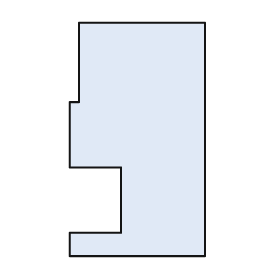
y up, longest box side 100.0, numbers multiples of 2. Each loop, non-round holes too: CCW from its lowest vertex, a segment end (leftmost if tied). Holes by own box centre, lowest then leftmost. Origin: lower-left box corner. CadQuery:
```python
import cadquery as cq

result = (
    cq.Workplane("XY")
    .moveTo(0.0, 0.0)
    .lineTo(58.0, 0.0)
    .lineTo(58.0, 100.0)
    .lineTo(4.0, 100.0)
    .lineTo(4.0, 66.0)
    .lineTo(0.0, 66.0)
    .lineTo(0.0, 38.0)
    .lineTo(22.0, 38.0)
    .lineTo(22.0, 10.0)
    .lineTo(0.0, 10.0)
    .close()
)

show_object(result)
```